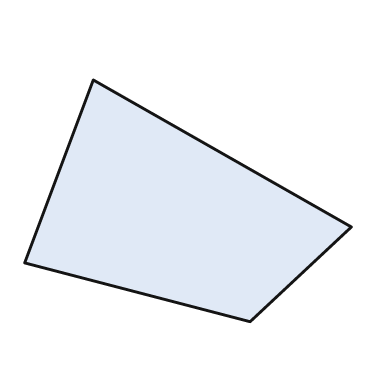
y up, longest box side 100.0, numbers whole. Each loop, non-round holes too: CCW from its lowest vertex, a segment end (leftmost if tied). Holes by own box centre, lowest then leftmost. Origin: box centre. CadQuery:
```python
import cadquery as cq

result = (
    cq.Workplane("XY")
    .moveTo(19.0, -37.0)
    .lineTo(50.0, -8.0)
    .lineTo(-29.0, 37.0)
    .lineTo(-50.0, -19.0)
    .close()
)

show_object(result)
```